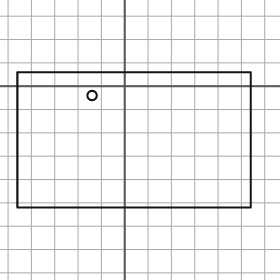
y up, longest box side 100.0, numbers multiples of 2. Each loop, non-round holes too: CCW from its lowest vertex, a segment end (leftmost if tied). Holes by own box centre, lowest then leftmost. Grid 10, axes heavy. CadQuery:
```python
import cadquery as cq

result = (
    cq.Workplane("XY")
    .moveTo(-46.0, -52.0)
    .lineTo(54.0, -52.0)
    .lineTo(54.0, 6.0)
    .lineTo(-46.0, 6.0)
    .close()
    .moveTo(-14.0, -4.0)
    .circle(2.0)
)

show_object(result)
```